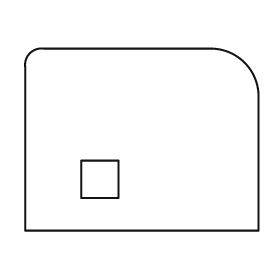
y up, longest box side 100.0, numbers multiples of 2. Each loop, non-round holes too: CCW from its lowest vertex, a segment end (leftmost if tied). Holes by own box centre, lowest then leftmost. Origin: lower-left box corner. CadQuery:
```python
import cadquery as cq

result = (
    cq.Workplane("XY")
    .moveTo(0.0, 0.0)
    .lineTo(100.0, 0.0)
    .lineTo(100.0, 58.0)
    .threePointArc((94.0, 72.0), (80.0, 78.0))
    .lineTo(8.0, 78.0)
    .threePointArc((2.0, 76.0), (0.0, 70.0))
    .close()
    .moveTo(24.0, 14.0)
    .lineTo(40.0, 14.0)
    .lineTo(40.0, 30.0)
    .lineTo(24.0, 30.0)
    .close()
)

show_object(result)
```